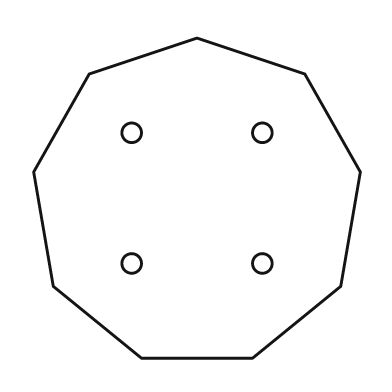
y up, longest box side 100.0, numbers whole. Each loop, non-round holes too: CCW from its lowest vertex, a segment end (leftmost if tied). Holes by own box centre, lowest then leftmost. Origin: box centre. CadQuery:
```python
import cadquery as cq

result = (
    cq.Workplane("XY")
    .moveTo(-17.0, -49.0)
    .lineTo(17.0, -49.0)
    .lineTo(44.0, -27.0)
    .lineTo(50.0, 8.0)
    .lineTo(33.0, 38.0)
    .lineTo(0.0, 49.0)
    .lineTo(-33.0, 38.0)
    .lineTo(-50.0, 8.0)
    .lineTo(-44.0, -27.0)
    .close()
    .moveTo(-20.0, -20.0)
    .circle(3.0)
    .moveTo(20.0, -20.0)
    .circle(3.0)
    .moveTo(-20.0, 20.0)
    .circle(3.0)
    .moveTo(20.0, 20.0)
    .circle(3.0)
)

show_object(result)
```